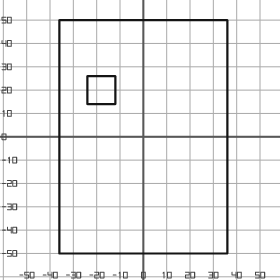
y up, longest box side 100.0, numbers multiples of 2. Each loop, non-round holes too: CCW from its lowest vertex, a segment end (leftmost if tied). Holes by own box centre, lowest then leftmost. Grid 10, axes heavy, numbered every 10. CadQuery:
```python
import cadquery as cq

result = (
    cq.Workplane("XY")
    .moveTo(-36.0, -50.0)
    .lineTo(36.0, -50.0)
    .lineTo(36.0, 50.0)
    .lineTo(-36.0, 50.0)
    .close()
    .moveTo(-24.0, 14.0)
    .lineTo(-12.0, 14.0)
    .lineTo(-12.0, 26.0)
    .lineTo(-24.0, 26.0)
    .close()
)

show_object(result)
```